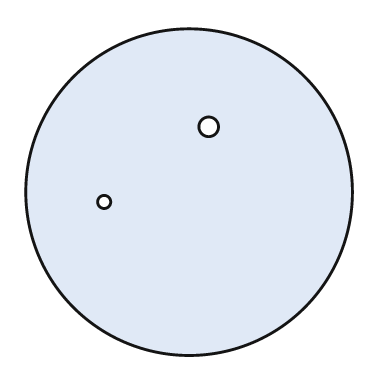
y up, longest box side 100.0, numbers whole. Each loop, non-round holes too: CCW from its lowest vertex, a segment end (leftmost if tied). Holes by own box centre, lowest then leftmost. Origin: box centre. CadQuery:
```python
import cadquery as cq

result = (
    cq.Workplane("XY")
    .moveTo(0.0, 0.0)
    .circle(50.0)
    .moveTo(-26.0, -3.0)
    .circle(2.0)
    .moveTo(6.0, 20.0)
    .circle(3.0)
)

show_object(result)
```